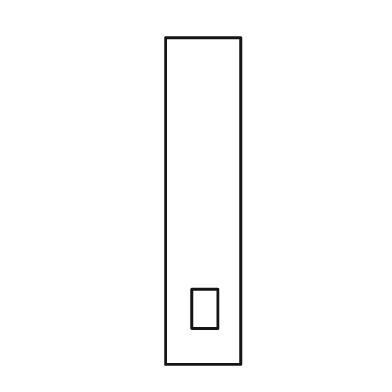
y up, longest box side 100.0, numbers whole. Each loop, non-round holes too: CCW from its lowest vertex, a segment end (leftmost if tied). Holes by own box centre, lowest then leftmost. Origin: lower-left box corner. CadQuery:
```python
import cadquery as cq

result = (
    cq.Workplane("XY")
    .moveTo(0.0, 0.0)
    .lineTo(23.0, 0.0)
    .lineTo(23.0, 100.0)
    .lineTo(0.0, 100.0)
    .close()
    .moveTo(8.0, 11.0)
    .lineTo(16.0, 11.0)
    .lineTo(16.0, 23.0)
    .lineTo(8.0, 23.0)
    .close()
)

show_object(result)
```